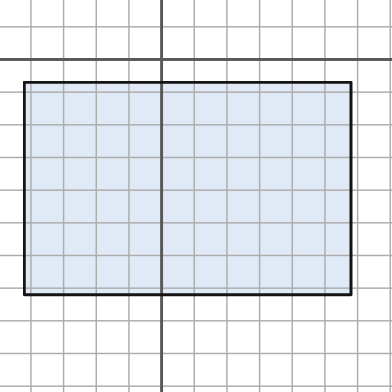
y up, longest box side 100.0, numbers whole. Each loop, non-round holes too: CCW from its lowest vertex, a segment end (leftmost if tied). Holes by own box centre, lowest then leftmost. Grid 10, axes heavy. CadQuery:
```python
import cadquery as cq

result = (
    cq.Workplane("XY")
    .moveTo(-42.0, -72.0)
    .lineTo(58.0, -72.0)
    .lineTo(58.0, -7.0)
    .lineTo(-42.0, -7.0)
    .close()
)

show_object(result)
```